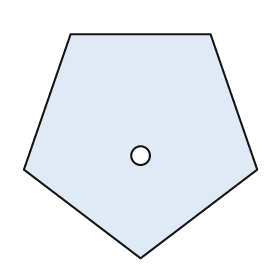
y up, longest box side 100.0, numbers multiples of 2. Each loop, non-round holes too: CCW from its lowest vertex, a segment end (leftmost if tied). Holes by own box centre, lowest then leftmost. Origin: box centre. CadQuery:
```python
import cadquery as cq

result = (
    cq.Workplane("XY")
    .moveTo(0.0, -48.0)
    .lineTo(50.0, -10.0)
    .lineTo(30.0, 48.0)
    .lineTo(-30.0, 48.0)
    .lineTo(-50.0, -10.0)
    .close()
    .moveTo(0.0, -4.0)
    .circle(4.0)
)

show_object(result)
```